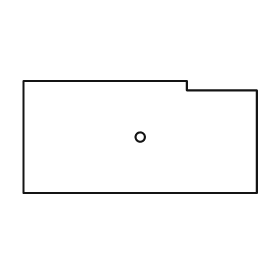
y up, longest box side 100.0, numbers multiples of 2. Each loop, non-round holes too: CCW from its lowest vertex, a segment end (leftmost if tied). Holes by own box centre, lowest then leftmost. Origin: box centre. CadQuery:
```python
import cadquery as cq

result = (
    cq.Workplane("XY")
    .moveTo(-50.0, -24.0)
    .lineTo(50.0, -24.0)
    .lineTo(50.0, 20.0)
    .lineTo(20.0, 20.0)
    .lineTo(20.0, 24.0)
    .lineTo(-50.0, 24.0)
    .close()
    .moveTo(0.0, 0.0)
    .circle(2.0)
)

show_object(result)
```